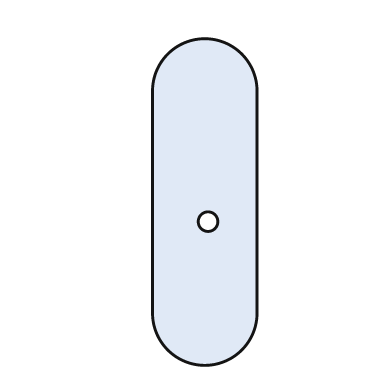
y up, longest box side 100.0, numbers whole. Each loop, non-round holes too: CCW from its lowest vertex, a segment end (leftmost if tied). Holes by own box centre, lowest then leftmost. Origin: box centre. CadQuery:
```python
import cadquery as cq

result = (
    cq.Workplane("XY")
    .moveTo(-16.0, -34.0)
    .threePointArc((0.0, -50.0), (16.0, -34.0))
    .lineTo(16.0, 34.0)
    .threePointArc((0.0, 50.0), (-16.0, 34.0))
    .close()
    .moveTo(1.0, -6.0)
    .circle(3.0)
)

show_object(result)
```